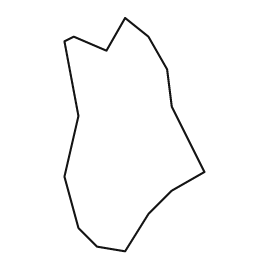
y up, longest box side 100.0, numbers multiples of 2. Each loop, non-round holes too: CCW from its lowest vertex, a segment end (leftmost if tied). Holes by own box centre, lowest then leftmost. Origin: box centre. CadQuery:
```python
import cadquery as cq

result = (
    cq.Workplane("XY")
    .moveTo(-4.0, -50.0)
    .lineTo(6.0, -34.0)
    .lineTo(16.0, -24.0)
    .lineTo(30.0, -16.0)
    .lineTo(16.0, 12.0)
    .lineTo(14.0, 28.0)
    .lineTo(6.0, 42.0)
    .lineTo(-4.0, 50.0)
    .lineTo(-12.0, 36.0)
    .lineTo(-26.0, 42.0)
    .lineTo(-30.0, 40.0)
    .lineTo(-24.0, 8.0)
    .lineTo(-30.0, -18.0)
    .lineTo(-24.0, -40.0)
    .lineTo(-16.0, -48.0)
    .close()
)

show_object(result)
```